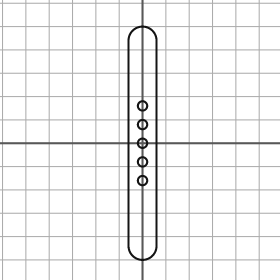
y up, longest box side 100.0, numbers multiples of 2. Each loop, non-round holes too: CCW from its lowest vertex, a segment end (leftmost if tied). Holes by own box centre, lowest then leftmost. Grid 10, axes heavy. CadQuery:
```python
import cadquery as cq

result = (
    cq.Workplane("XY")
    .moveTo(-6.0, -44.0)
    .threePointArc((0.0, -50.0), (6.0, -44.0))
    .lineTo(6.0, 44.0)
    .threePointArc((0.0, 50.0), (-6.0, 44.0))
    .close()
    .moveTo(0.0, -16.0)
    .circle(2.0)
    .moveTo(0.0, -8.0)
    .circle(2.0)
    .moveTo(0.0, 0.0)
    .circle(2.0)
    .moveTo(0.0, 8.0)
    .circle(2.0)
    .moveTo(0.0, 16.0)
    .circle(2.0)
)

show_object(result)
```